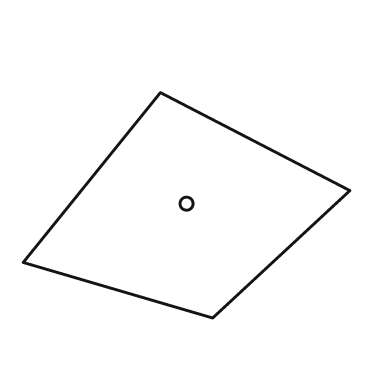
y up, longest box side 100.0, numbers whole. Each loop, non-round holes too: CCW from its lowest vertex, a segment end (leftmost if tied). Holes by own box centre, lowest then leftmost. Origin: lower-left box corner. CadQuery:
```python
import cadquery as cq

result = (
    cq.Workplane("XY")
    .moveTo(58.0, 0.0)
    .lineTo(100.0, 39.0)
    .lineTo(42.0, 69.0)
    .lineTo(0.0, 17.0)
    .close()
    .moveTo(50.0, 35.0)
    .circle(2.0)
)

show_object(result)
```